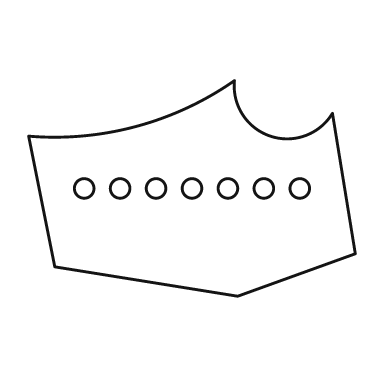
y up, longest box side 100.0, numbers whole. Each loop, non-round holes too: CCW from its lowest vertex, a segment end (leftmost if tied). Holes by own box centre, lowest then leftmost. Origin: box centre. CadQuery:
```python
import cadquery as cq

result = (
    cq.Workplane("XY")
    .moveTo(14.0, -33.0)
    .lineTo(50.0, -20.0)
    .lineTo(43.0, 23.0)
    .threePointArc((24.0, 16.0), (13.0, 33.0))
    .threePointArc((-17.0, 19.0), (-50.0, 16.0))
    .lineTo(-42.0, -24.0)
    .close()
    .moveTo(-33.0, 0.0)
    .circle(3.0)
    .moveTo(-22.0, 0.0)
    .circle(3.0)
    .moveTo(-11.0, 0.0)
    .circle(3.0)
    .moveTo(0.0, 0.0)
    .circle(3.0)
    .moveTo(11.0, 0.0)
    .circle(3.0)
    .moveTo(22.0, 0.0)
    .circle(3.0)
    .moveTo(33.0, 0.0)
    .circle(3.0)
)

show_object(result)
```